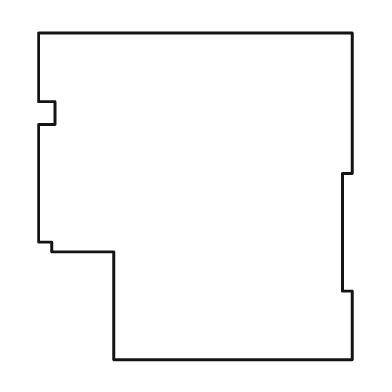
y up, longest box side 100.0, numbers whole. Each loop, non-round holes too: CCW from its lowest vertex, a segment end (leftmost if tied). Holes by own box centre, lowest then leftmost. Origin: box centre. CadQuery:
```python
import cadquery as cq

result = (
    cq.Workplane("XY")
    .moveTo(-25.0, -50.0)
    .lineTo(48.0, -50.0)
    .lineTo(48.0, -29.0)
    .lineTo(45.0, -29.0)
    .lineTo(45.0, 7.0)
    .lineTo(48.0, 7.0)
    .lineTo(48.0, 50.0)
    .lineTo(-48.0, 50.0)
    .lineTo(-48.0, 29.0)
    .lineTo(-43.0, 29.0)
    .lineTo(-43.0, 22.0)
    .lineTo(-48.0, 22.0)
    .lineTo(-48.0, -14.0)
    .lineTo(-44.0, -14.0)
    .lineTo(-44.0, -17.0)
    .lineTo(-25.0, -17.0)
    .close()
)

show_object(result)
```